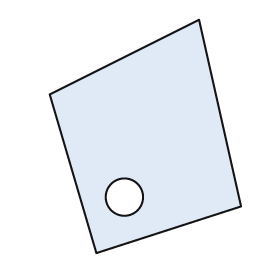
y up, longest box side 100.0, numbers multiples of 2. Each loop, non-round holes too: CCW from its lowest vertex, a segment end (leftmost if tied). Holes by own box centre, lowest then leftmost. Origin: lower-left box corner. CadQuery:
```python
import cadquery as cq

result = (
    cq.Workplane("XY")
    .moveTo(20.0, 0.0)
    .lineTo(82.0, 20.0)
    .lineTo(64.0, 100.0)
    .lineTo(0.0, 68.0)
    .close()
    .moveTo(32.0, 24.0)
    .circle(8.0)
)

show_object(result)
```